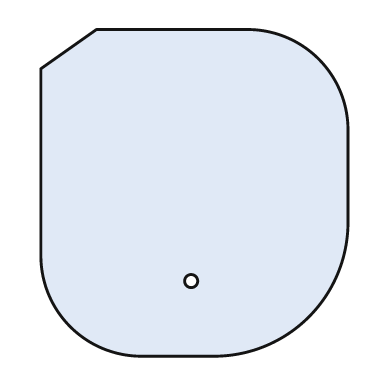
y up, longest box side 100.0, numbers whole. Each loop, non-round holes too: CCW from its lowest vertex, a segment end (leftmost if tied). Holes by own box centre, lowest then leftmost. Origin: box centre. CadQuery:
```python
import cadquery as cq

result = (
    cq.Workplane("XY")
    .moveTo(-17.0, -50.0)
    .lineTo(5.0, -50.0)
    .threePointArc((35.0, -38.0), (47.0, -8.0))
    .lineTo(47.0, 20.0)
    .threePointArc((38.0, 41.0), (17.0, 50.0))
    .lineTo(-30.0, 50.0)
    .lineTo(-47.0, 38.0)
    .lineTo(-47.0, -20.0)
    .threePointArc((-38.0, -41.0), (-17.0, -50.0))
    .close()
    .moveTo(-1.0, -27.0)
    .circle(2.0)
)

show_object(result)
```